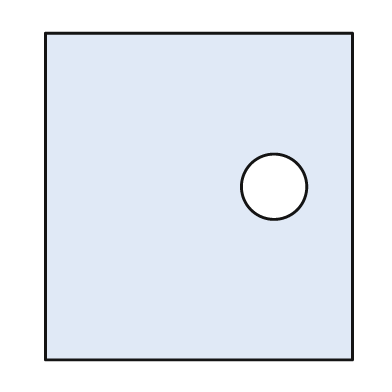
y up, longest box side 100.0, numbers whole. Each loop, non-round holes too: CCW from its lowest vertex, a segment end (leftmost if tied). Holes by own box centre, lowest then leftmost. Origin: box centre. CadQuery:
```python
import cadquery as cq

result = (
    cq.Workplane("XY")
    .moveTo(-47.0, -50.0)
    .lineTo(47.0, -50.0)
    .lineTo(47.0, 50.0)
    .lineTo(-47.0, 50.0)
    .close()
    .moveTo(23.0, 3.0)
    .circle(10.0)
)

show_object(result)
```